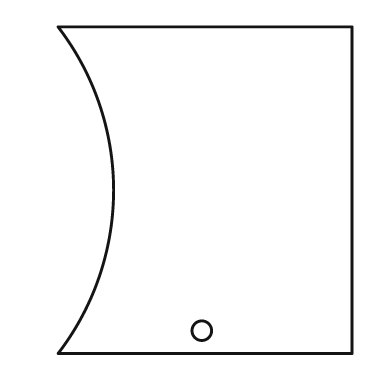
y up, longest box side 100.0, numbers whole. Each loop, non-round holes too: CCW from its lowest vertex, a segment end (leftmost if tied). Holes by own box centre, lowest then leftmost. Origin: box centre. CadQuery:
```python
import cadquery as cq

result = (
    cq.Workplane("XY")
    .moveTo(-45.0, -50.0)
    .lineTo(45.0, -50.0)
    .lineTo(45.0, 50.0)
    .lineTo(-45.0, 50.0)
    .threePointArc((-28.0, 0.0), (-45.0, -50.0))
    .close()
    .moveTo(-1.0, -43.0)
    .circle(3.0)
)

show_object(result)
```